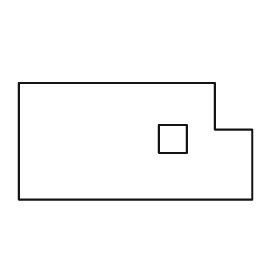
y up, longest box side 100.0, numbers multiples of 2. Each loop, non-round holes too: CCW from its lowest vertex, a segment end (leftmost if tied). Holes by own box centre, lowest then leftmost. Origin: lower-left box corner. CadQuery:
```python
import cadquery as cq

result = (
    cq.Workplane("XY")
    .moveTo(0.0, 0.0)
    .lineTo(100.0, 0.0)
    .lineTo(100.0, 30.0)
    .lineTo(84.0, 30.0)
    .lineTo(84.0, 50.0)
    .lineTo(0.0, 50.0)
    .close()
    .moveTo(60.0, 20.0)
    .lineTo(72.0, 20.0)
    .lineTo(72.0, 32.0)
    .lineTo(60.0, 32.0)
    .close()
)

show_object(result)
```